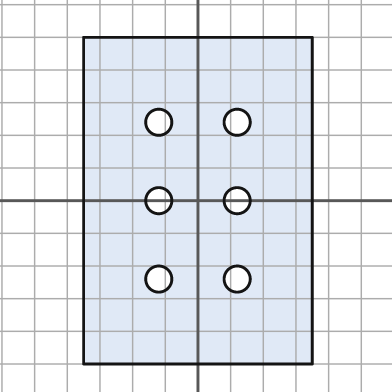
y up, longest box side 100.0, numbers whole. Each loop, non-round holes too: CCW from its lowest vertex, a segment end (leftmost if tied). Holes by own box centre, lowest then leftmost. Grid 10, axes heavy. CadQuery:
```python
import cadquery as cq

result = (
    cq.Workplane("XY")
    .moveTo(-35.0, -50.0)
    .lineTo(35.0, -50.0)
    .lineTo(35.0, 50.0)
    .lineTo(-35.0, 50.0)
    .close()
    .moveTo(-12.0, -24.0)
    .circle(4.0)
    .moveTo(12.0, -24.0)
    .circle(4.0)
    .moveTo(-12.0, 0.0)
    .circle(4.0)
    .moveTo(12.0, 0.0)
    .circle(4.0)
    .moveTo(-12.0, 24.0)
    .circle(4.0)
    .moveTo(12.0, 24.0)
    .circle(4.0)
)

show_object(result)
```